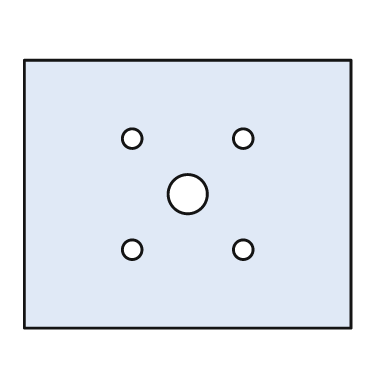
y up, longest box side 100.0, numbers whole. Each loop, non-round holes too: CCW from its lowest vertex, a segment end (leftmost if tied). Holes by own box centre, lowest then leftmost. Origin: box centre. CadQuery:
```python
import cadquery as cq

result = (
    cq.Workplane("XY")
    .moveTo(-50.0, -41.0)
    .lineTo(50.0, -41.0)
    .lineTo(50.0, 41.0)
    .lineTo(-50.0, 41.0)
    .close()
    .moveTo(-17.0, -17.0)
    .circle(3.0)
    .moveTo(17.0, -17.0)
    .circle(3.0)
    .moveTo(0.0, 0.0)
    .circle(6.0)
    .moveTo(-17.0, 17.0)
    .circle(3.0)
    .moveTo(17.0, 17.0)
    .circle(3.0)
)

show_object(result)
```